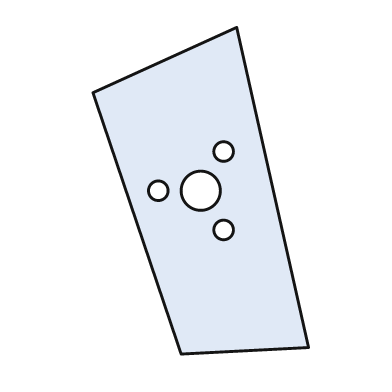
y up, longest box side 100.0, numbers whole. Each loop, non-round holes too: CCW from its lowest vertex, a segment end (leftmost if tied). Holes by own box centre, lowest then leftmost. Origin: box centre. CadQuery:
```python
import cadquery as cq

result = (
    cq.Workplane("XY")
    .moveTo(-6.0, -50.0)
    .lineTo(33.0, -48.0)
    .lineTo(11.0, 50.0)
    .lineTo(-33.0, 30.0)
    .close()
    .moveTo(7.0, -12.0)
    .circle(3.0)
    .moveTo(-13.0, 0.0)
    .circle(3.0)
    .moveTo(0.0, 0.0)
    .circle(6.0)
    .moveTo(7.0, 12.0)
    .circle(3.0)
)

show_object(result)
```